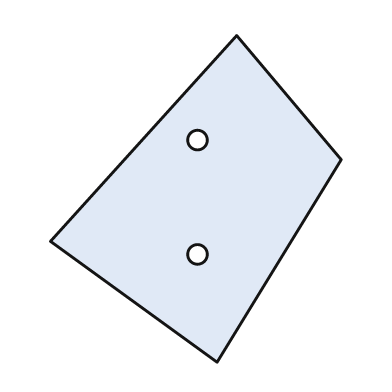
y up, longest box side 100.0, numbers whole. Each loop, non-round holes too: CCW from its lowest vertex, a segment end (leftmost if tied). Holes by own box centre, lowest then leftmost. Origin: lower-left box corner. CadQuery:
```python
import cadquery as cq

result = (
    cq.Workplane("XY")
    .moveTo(51.0, 0.0)
    .lineTo(89.0, 62.0)
    .lineTo(57.0, 100.0)
    .lineTo(0.0, 37.0)
    .close()
    .moveTo(45.0, 33.0)
    .circle(3.0)
    .moveTo(45.0, 68.0)
    .circle(3.0)
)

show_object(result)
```